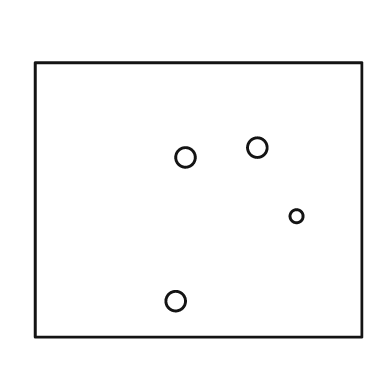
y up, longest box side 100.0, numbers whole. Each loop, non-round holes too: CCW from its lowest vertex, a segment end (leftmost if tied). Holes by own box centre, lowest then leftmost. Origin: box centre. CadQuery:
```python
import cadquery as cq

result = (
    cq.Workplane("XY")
    .moveTo(-50.0, -42.0)
    .lineTo(50.0, -42.0)
    .lineTo(50.0, 42.0)
    .lineTo(-50.0, 42.0)
    .close()
    .moveTo(-7.0, -31.0)
    .circle(3.0)
    .moveTo(30.0, -5.0)
    .circle(2.0)
    .moveTo(-4.0, 13.0)
    .circle(3.0)
    .moveTo(18.0, 16.0)
    .circle(3.0)
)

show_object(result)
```